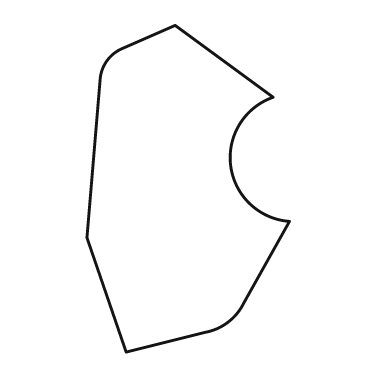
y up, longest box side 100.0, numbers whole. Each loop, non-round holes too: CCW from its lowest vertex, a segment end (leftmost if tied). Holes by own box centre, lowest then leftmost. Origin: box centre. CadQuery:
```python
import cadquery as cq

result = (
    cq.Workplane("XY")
    .moveTo(-19.0, -50.0)
    .lineTo(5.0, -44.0)
    .threePointArc((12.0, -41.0), (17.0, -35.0))
    .lineTo(31.0, -10.0)
    .threePointArc((13.0, 7.0), (26.0, 28.0))
    .lineTo(-4.0, 50.0)
    .lineTo(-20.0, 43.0)
    .threePointArc((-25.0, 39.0), (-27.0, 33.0))
    .lineTo(-31.0, -15.0)
    .close()
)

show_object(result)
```